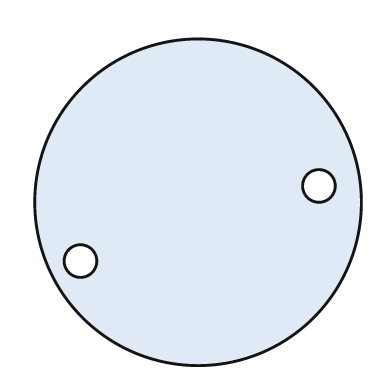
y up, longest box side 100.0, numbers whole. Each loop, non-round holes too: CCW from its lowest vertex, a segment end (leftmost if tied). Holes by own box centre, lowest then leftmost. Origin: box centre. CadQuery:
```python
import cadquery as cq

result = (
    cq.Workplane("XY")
    .moveTo(0.0, 0.0)
    .circle(50.0)
    .moveTo(-36.0, -18.0)
    .circle(5.0)
    .moveTo(37.0, 5.0)
    .circle(5.0)
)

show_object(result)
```